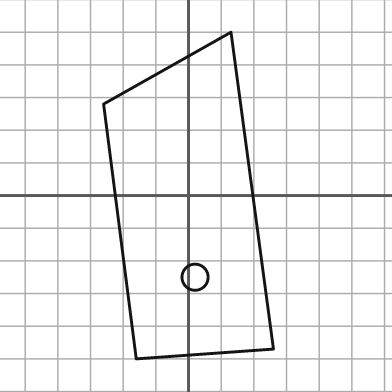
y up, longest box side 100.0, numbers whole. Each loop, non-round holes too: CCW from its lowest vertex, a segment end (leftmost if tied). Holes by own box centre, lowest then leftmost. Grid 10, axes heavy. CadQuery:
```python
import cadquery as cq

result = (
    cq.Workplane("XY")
    .moveTo(-16.0, -50.0)
    .lineTo(26.0, -47.0)
    .lineTo(13.0, 50.0)
    .lineTo(-26.0, 28.0)
    .close()
    .moveTo(2.0, -25.0)
    .circle(4.0)
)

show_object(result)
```